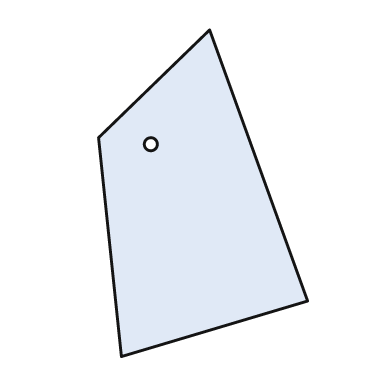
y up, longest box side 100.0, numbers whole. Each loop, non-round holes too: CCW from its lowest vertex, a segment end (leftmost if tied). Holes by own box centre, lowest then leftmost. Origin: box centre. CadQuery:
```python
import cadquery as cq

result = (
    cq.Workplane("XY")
    .moveTo(-25.0, -50.0)
    .lineTo(32.0, -33.0)
    .lineTo(2.0, 50.0)
    .lineTo(-32.0, 17.0)
    .close()
    .moveTo(-16.0, 15.0)
    .circle(2.0)
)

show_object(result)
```